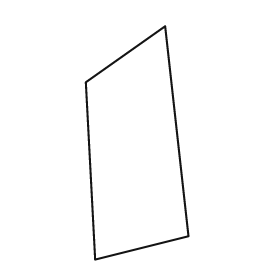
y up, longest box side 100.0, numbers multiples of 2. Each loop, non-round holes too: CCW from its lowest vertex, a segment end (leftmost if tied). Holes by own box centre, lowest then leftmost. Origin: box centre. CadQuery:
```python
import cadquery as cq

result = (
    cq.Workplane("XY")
    .moveTo(-18.0, -50.0)
    .lineTo(22.0, -40.0)
    .lineTo(12.0, 50.0)
    .lineTo(-22.0, 26.0)
    .close()
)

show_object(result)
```